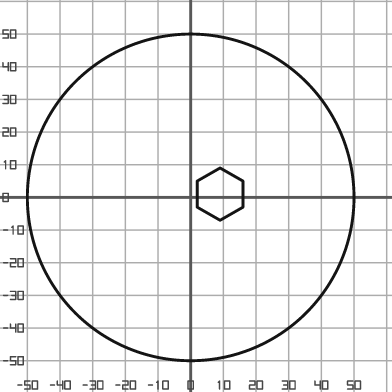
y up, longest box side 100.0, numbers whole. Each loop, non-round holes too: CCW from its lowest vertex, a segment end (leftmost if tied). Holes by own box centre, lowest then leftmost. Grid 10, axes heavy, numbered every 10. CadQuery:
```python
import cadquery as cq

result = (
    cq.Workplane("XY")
    .moveTo(0.0, 0.0)
    .circle(50.0)
    .moveTo(9.0, -7.0)
    .lineTo(16.0, -3.0)
    .lineTo(16.0, 5.0)
    .lineTo(9.0, 9.0)
    .lineTo(2.0, 5.0)
    .lineTo(2.0, -3.0)
    .close()
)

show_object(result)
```